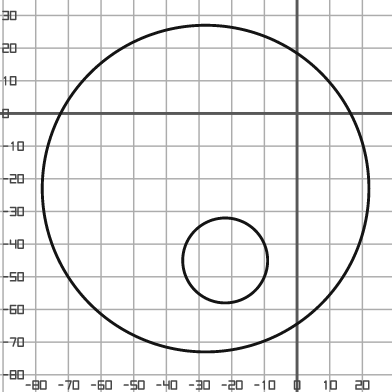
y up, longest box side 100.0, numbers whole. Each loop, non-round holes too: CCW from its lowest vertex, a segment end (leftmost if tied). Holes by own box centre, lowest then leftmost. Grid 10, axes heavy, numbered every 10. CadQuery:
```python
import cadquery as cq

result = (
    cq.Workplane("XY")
    .moveTo(-28.0, -23.0)
    .circle(50.0)
    .moveTo(-22.0, -45.0)
    .circle(13.0)
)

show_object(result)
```